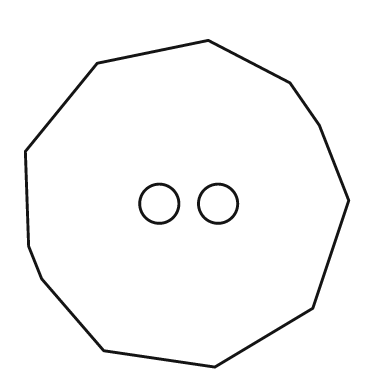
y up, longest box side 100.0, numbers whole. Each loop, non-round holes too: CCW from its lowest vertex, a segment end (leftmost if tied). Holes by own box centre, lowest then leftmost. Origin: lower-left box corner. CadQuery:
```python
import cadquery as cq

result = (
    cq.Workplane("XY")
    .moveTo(58.0, 0.0)
    .lineTo(88.0, 18.0)
    .lineTo(99.0, 51.0)
    .lineTo(90.0, 74.0)
    .lineTo(81.0, 87.0)
    .lineTo(56.0, 100.0)
    .lineTo(22.0, 93.0)
    .lineTo(0.0, 66.0)
    .lineTo(1.0, 37.0)
    .lineTo(5.0, 27.0)
    .lineTo(24.0, 5.0)
    .close()
    .moveTo(41.0, 50.0)
    .circle(6.0)
    .moveTo(59.0, 50.0)
    .circle(6.0)
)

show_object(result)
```